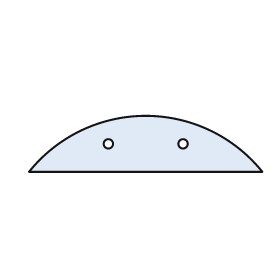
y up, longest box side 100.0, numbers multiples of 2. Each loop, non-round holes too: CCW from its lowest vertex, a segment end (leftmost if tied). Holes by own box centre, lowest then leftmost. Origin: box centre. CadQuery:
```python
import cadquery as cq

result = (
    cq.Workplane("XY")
    .moveTo(-50.0, -12.0)
    .lineTo(50.0, -12.0)
    .threePointArc((0.0, 12.0), (-50.0, -12.0))
    .close()
    .moveTo(-16.0, 0.0)
    .circle(2.0)
    .moveTo(16.0, 0.0)
    .circle(2.0)
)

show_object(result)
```